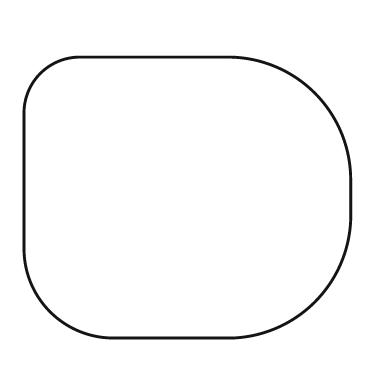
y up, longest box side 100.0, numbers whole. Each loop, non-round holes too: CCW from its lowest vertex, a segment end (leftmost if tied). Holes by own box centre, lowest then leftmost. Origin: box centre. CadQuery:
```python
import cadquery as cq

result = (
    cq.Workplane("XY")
    .moveTo(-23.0, -43.0)
    .lineTo(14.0, -43.0)
    .threePointArc((39.0, -32.0), (50.0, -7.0))
    .lineTo(50.0, 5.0)
    .threePointArc((39.0, 32.0), (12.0, 43.0))
    .lineTo(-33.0, 43.0)
    .threePointArc((-45.0, 38.0), (-50.0, 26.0))
    .lineTo(-50.0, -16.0)
    .threePointArc((-42.0, -35.0), (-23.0, -43.0))
    .close()
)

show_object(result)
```